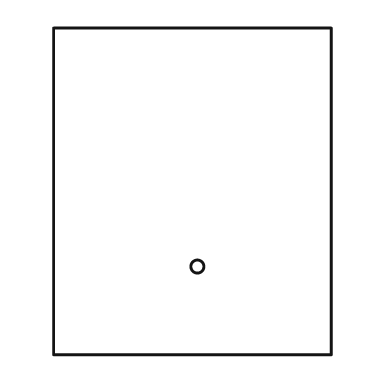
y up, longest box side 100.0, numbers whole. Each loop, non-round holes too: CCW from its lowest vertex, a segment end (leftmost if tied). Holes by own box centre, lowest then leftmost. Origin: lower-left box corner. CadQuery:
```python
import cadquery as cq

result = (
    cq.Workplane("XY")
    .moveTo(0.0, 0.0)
    .lineTo(85.0, 0.0)
    .lineTo(85.0, 100.0)
    .lineTo(0.0, 100.0)
    .close()
    .moveTo(44.0, 27.0)
    .circle(2.0)
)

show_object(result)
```